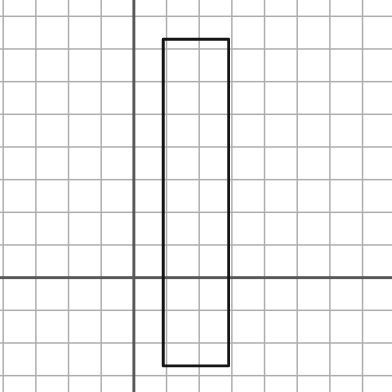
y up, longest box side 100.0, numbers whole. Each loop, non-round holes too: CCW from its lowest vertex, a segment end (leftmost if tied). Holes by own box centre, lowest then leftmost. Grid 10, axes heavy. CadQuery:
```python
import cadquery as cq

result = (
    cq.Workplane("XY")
    .moveTo(9.0, -27.0)
    .lineTo(29.0, -27.0)
    .lineTo(29.0, 73.0)
    .lineTo(9.0, 73.0)
    .close()
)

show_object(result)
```